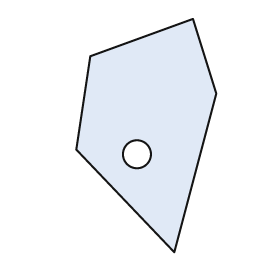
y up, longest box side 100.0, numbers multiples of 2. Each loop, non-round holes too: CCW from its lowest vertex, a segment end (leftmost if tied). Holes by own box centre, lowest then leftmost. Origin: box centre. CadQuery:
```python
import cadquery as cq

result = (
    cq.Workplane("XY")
    .moveTo(12.0, -50.0)
    .lineTo(30.0, 18.0)
    .lineTo(20.0, 50.0)
    .lineTo(-24.0, 34.0)
    .lineTo(-30.0, -6.0)
    .close()
    .moveTo(-4.0, -8.0)
    .circle(6.0)
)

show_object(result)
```